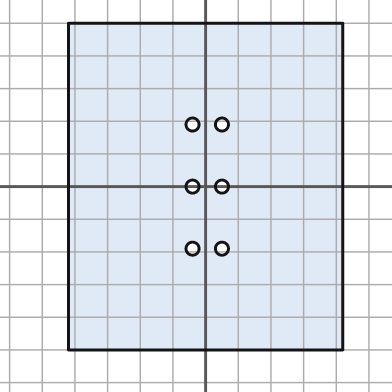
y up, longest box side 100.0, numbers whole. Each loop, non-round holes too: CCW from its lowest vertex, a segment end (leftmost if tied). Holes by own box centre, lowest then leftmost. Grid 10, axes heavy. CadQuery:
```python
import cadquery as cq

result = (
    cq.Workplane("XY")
    .moveTo(-42.0, -50.0)
    .lineTo(42.0, -50.0)
    .lineTo(42.0, 50.0)
    .lineTo(-42.0, 50.0)
    .close()
    .moveTo(-4.0, -19.0)
    .circle(2.0)
    .moveTo(5.0, -19.0)
    .circle(2.0)
    .moveTo(-4.0, 0.0)
    .circle(2.0)
    .moveTo(5.0, 0.0)
    .circle(2.0)
    .moveTo(-4.0, 19.0)
    .circle(2.0)
    .moveTo(5.0, 19.0)
    .circle(2.0)
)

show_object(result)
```